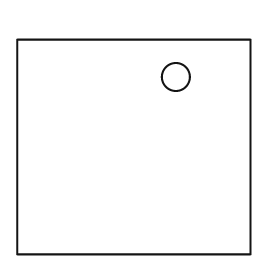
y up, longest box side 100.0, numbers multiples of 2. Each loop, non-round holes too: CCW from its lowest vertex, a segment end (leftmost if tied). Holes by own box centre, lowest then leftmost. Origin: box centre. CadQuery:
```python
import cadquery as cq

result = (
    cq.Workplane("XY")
    .moveTo(-50.0, -46.0)
    .lineTo(50.0, -46.0)
    .lineTo(50.0, 46.0)
    .lineTo(-50.0, 46.0)
    .close()
    .moveTo(18.0, 30.0)
    .circle(6.0)
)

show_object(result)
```